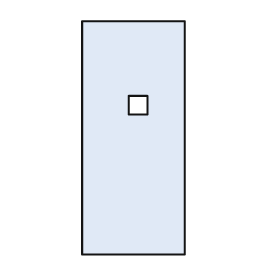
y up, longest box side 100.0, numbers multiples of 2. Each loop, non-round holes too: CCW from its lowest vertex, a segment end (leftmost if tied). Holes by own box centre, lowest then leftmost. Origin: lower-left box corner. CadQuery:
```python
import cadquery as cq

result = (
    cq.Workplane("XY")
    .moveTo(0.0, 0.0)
    .lineTo(44.0, 0.0)
    .lineTo(44.0, 100.0)
    .lineTo(0.0, 100.0)
    .close()
    .moveTo(20.0, 60.0)
    .lineTo(28.0, 60.0)
    .lineTo(28.0, 68.0)
    .lineTo(20.0, 68.0)
    .close()
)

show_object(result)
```